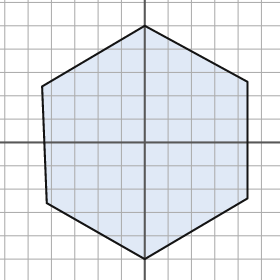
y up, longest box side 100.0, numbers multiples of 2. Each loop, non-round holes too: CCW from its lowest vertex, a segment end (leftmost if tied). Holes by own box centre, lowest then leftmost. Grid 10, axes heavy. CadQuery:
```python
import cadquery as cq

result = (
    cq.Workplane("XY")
    .moveTo(0.0, -50.0)
    .lineTo(44.0, -24.0)
    .lineTo(44.0, 26.0)
    .lineTo(0.0, 50.0)
    .lineTo(-44.0, 24.0)
    .lineTo(-42.0, -26.0)
    .close()
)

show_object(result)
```